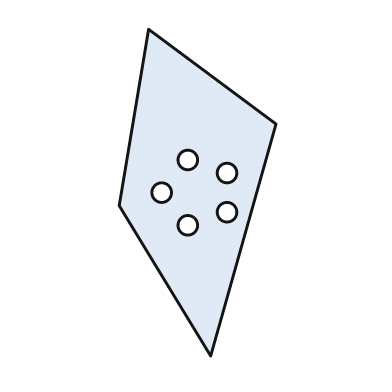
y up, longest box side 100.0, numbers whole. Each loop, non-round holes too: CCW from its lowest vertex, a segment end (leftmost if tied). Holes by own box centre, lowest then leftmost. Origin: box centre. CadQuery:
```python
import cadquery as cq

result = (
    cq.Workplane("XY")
    .moveTo(4.0, -50.0)
    .lineTo(24.0, 21.0)
    .lineTo(-15.0, 50.0)
    .lineTo(-24.0, -4.0)
    .close()
    .moveTo(-3.0, -10.0)
    .circle(3.0)
    .moveTo(9.0, -6.0)
    .circle(3.0)
    .moveTo(-11.0, 0.0)
    .circle(3.0)
    .moveTo(9.0, 6.0)
    .circle(3.0)
    .moveTo(-3.0, 10.0)
    .circle(3.0)
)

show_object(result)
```